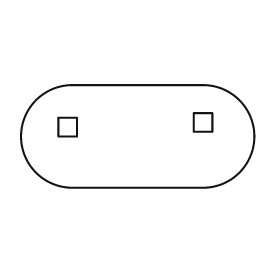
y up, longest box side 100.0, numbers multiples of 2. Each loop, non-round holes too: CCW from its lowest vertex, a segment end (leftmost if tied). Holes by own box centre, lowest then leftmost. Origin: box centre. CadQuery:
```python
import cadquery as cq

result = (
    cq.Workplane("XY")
    .moveTo(-28.0, -22.0)
    .lineTo(28.0, -22.0)
    .threePointArc((50.0, 0.0), (28.0, 22.0))
    .lineTo(-28.0, 22.0)
    .threePointArc((-50.0, 0.0), (-28.0, -22.0))
    .close()
    .moveTo(-34.0, 0.0)
    .lineTo(-26.0, 0.0)
    .lineTo(-26.0, 8.0)
    .lineTo(-34.0, 8.0)
    .close()
    .moveTo(24.0, 2.0)
    .lineTo(32.0, 2.0)
    .lineTo(32.0, 10.0)
    .lineTo(24.0, 10.0)
    .close()
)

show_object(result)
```